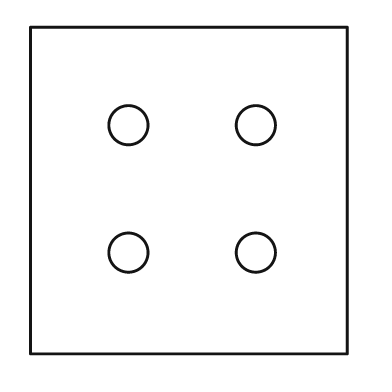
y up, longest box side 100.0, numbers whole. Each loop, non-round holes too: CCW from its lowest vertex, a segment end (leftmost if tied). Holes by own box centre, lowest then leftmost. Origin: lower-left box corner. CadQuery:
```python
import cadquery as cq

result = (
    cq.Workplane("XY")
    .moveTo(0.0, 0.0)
    .lineTo(97.0, 0.0)
    .lineTo(97.0, 100.0)
    .lineTo(0.0, 100.0)
    .close()
    .moveTo(30.0, 31.0)
    .circle(6.0)
    .moveTo(69.0, 31.0)
    .circle(6.0)
    .moveTo(30.0, 70.0)
    .circle(6.0)
    .moveTo(69.0, 70.0)
    .circle(6.0)
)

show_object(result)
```